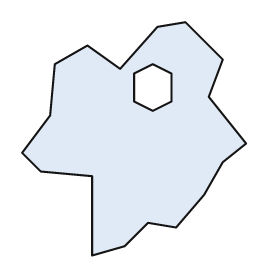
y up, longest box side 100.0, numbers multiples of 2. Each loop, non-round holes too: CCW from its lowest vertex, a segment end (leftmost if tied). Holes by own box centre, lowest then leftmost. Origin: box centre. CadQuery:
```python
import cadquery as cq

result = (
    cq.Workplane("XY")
    .moveTo(-18.0, -50.0)
    .lineTo(-4.0, -46.0)
    .lineTo(6.0, -36.0)
    .lineTo(18.0, -38.0)
    .lineTo(30.0, -24.0)
    .lineTo(38.0, -10.0)
    .lineTo(48.0, -2.0)
    .lineTo(32.0, 18.0)
    .lineTo(38.0, 34.0)
    .lineTo(22.0, 50.0)
    .lineTo(10.0, 48.0)
    .lineTo(-6.0, 30.0)
    .lineTo(-20.0, 40.0)
    .lineTo(-34.0, 32.0)
    .lineTo(-36.0, 10.0)
    .lineTo(-48.0, -6.0)
    .lineTo(-40.0, -14.0)
    .lineTo(-18.0, -16.0)
    .close()
    .moveTo(8.0, 12.0)
    .lineTo(16.0, 16.0)
    .lineTo(16.0, 28.0)
    .lineTo(8.0, 32.0)
    .lineTo(0.0, 28.0)
    .lineTo(0.0, 16.0)
    .close()
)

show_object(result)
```